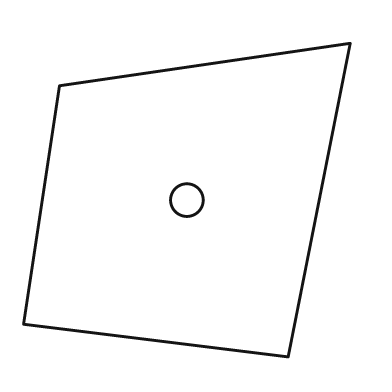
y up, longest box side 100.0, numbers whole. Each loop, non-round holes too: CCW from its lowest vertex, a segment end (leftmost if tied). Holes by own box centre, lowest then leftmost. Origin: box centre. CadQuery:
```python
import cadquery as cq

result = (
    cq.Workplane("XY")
    .moveTo(31.0, -48.0)
    .lineTo(50.0, 48.0)
    .lineTo(-39.0, 35.0)
    .lineTo(-50.0, -38.0)
    .close()
    .moveTo(0.0, 0.0)
    .circle(5.0)
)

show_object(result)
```